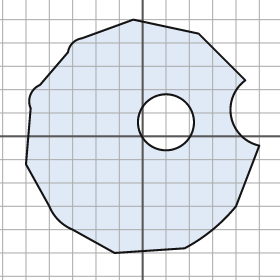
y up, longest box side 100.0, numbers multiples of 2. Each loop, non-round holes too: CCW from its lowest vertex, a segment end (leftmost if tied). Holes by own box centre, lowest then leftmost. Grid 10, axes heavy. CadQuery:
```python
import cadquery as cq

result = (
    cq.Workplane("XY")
    .moveTo(-12.0, -50.0)
    .lineTo(18.0, -48.0)
    .threePointArc((30.0, -40.0), (40.0, -30.0))
    .lineTo(50.0, -4.0)
    .threePointArc((38.0, 8.0), (44.0, 24.0))
    .lineTo(24.0, 44.0)
    .lineTo(-4.0, 50.0)
    .lineTo(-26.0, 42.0)
    .threePointArc((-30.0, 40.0), (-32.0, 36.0))
    .lineTo(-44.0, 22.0)
    .threePointArc((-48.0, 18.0), (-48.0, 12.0))
    .lineTo(-50.0, -12.0)
    .lineTo(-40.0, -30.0)
    .threePointArc((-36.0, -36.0), (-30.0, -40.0))
    .close()
    .moveTo(10.0, 6.0)
    .circle(12.0)
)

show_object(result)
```